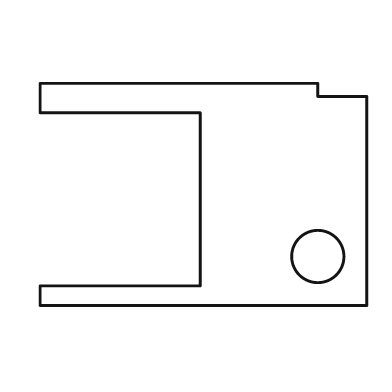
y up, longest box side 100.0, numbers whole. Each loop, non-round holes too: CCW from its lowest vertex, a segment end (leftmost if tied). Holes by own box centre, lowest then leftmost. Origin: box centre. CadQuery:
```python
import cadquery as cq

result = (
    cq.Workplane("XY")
    .moveTo(-50.0, -34.0)
    .lineTo(50.0, -34.0)
    .lineTo(50.0, 30.0)
    .lineTo(35.0, 30.0)
    .lineTo(35.0, 34.0)
    .lineTo(-50.0, 34.0)
    .lineTo(-50.0, 25.0)
    .lineTo(-1.0, 25.0)
    .lineTo(-1.0, -28.0)
    .lineTo(-50.0, -28.0)
    .close()
    .moveTo(35.0, -19.0)
    .circle(8.0)
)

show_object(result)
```